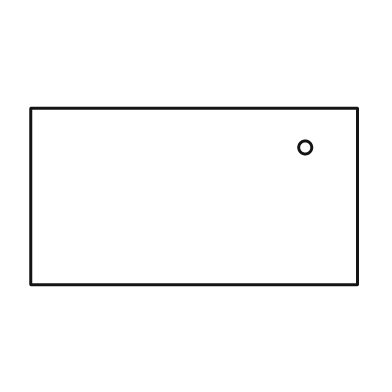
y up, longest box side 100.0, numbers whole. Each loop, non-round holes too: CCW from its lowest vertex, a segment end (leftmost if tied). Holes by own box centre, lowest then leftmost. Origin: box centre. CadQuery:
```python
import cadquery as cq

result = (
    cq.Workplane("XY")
    .moveTo(-50.0, -27.0)
    .lineTo(50.0, -27.0)
    .lineTo(50.0, 27.0)
    .lineTo(-50.0, 27.0)
    .close()
    .moveTo(34.0, 15.0)
    .circle(2.0)
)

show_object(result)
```